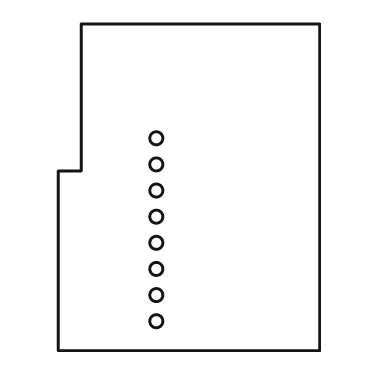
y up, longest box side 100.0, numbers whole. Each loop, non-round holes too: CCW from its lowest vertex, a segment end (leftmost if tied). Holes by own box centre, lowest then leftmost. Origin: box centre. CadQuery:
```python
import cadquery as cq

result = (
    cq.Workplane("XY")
    .moveTo(-40.0, -50.0)
    .lineTo(40.0, -50.0)
    .lineTo(40.0, 50.0)
    .lineTo(-33.0, 50.0)
    .lineTo(-33.0, 5.0)
    .lineTo(-40.0, 5.0)
    .close()
    .moveTo(-10.0, -41.0)
    .circle(2.0)
    .moveTo(-10.0, -33.0)
    .circle(2.0)
    .moveTo(-10.0, -25.0)
    .circle(2.0)
    .moveTo(-10.0, -17.0)
    .circle(2.0)
    .moveTo(-10.0, -9.0)
    .circle(2.0)
    .moveTo(-10.0, -1.0)
    .circle(2.0)
    .moveTo(-10.0, 7.0)
    .circle(2.0)
    .moveTo(-10.0, 15.0)
    .circle(2.0)
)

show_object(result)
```